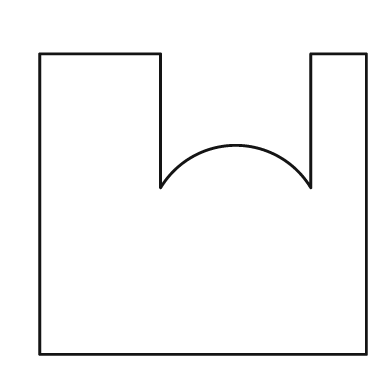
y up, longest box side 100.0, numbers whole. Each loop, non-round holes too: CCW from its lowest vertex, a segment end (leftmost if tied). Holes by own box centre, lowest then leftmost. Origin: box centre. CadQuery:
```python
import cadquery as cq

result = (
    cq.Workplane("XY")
    .moveTo(-50.0, -46.0)
    .lineTo(50.0, -46.0)
    .lineTo(50.0, 46.0)
    .lineTo(33.0, 46.0)
    .lineTo(33.0, 5.0)
    .threePointArc((10.0, 18.0), (-13.0, 5.0))
    .lineTo(-13.0, 46.0)
    .lineTo(-50.0, 46.0)
    .close()
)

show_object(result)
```